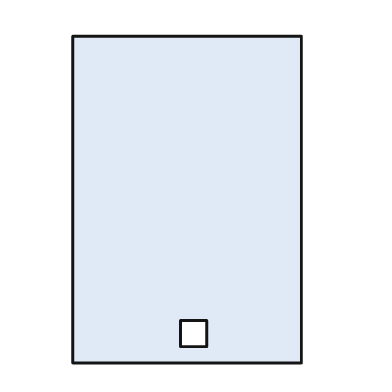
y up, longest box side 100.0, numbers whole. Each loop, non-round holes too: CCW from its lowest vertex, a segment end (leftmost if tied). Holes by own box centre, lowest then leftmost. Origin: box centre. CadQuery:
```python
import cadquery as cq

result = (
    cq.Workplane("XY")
    .moveTo(-35.0, -50.0)
    .lineTo(35.0, -50.0)
    .lineTo(35.0, 50.0)
    .lineTo(-35.0, 50.0)
    .close()
    .moveTo(-2.0, -45.0)
    .lineTo(6.0, -45.0)
    .lineTo(6.0, -37.0)
    .lineTo(-2.0, -37.0)
    .close()
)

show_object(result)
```